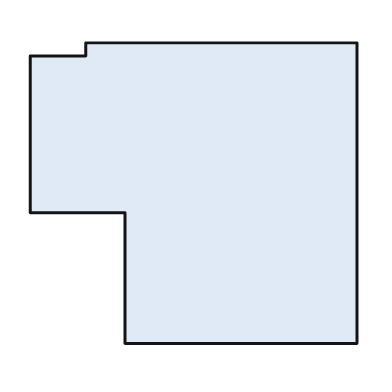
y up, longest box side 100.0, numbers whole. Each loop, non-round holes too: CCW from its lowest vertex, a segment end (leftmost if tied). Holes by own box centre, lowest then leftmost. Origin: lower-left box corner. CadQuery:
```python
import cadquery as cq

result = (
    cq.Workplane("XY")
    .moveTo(29.0, 0.0)
    .lineTo(100.0, 0.0)
    .lineTo(100.0, 92.0)
    .lineTo(17.0, 92.0)
    .lineTo(17.0, 88.0)
    .lineTo(0.0, 88.0)
    .lineTo(0.0, 40.0)
    .lineTo(29.0, 40.0)
    .close()
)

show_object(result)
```